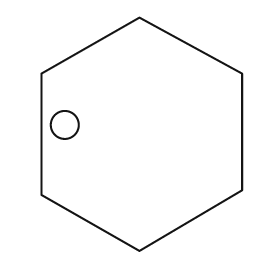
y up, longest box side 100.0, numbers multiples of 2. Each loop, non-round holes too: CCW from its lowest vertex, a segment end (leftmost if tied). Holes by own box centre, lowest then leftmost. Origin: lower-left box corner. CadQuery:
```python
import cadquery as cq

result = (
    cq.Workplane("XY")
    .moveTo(42.0, 0.0)
    .lineTo(86.0, 26.0)
    .lineTo(86.0, 76.0)
    .lineTo(42.0, 100.0)
    .lineTo(0.0, 76.0)
    .lineTo(0.0, 24.0)
    .close()
    .moveTo(10.0, 54.0)
    .circle(6.0)
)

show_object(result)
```